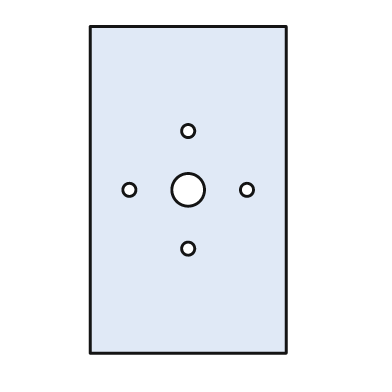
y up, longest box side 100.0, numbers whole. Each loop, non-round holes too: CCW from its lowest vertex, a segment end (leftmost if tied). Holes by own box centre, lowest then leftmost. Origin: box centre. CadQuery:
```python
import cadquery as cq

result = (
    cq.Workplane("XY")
    .moveTo(-30.0, -50.0)
    .lineTo(30.0, -50.0)
    .lineTo(30.0, 50.0)
    .lineTo(-30.0, 50.0)
    .close()
    .moveTo(0.0, -18.0)
    .circle(2.0)
    .moveTo(-18.0, 0.0)
    .circle(2.0)
    .moveTo(0.0, 0.0)
    .circle(5.0)
    .moveTo(18.0, 0.0)
    .circle(2.0)
    .moveTo(0.0, 18.0)
    .circle(2.0)
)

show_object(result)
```